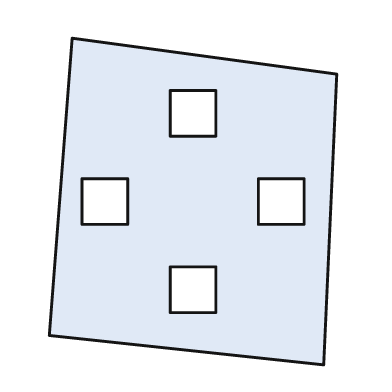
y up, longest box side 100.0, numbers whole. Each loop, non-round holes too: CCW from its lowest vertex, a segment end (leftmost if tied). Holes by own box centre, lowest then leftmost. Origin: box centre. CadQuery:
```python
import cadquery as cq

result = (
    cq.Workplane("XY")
    .moveTo(40.0, -50.0)
    .lineTo(44.0, 39.0)
    .lineTo(-37.0, 50.0)
    .lineTo(-44.0, -41.0)
    .close()
    .moveTo(-7.0, -34.0)
    .lineTo(7.0, -34.0)
    .lineTo(7.0, -20.0)
    .lineTo(-7.0, -20.0)
    .close()
    .moveTo(-34.0, -7.0)
    .lineTo(-20.0, -7.0)
    .lineTo(-20.0, 7.0)
    .lineTo(-34.0, 7.0)
    .close()
    .moveTo(20.0, -7.0)
    .lineTo(34.0, -7.0)
    .lineTo(34.0, 7.0)
    .lineTo(20.0, 7.0)
    .close()
    .moveTo(-7.0, 20.0)
    .lineTo(7.0, 20.0)
    .lineTo(7.0, 34.0)
    .lineTo(-7.0, 34.0)
    .close()
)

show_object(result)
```